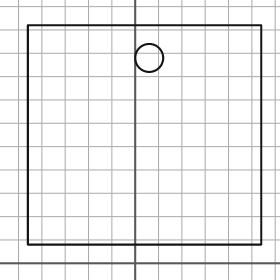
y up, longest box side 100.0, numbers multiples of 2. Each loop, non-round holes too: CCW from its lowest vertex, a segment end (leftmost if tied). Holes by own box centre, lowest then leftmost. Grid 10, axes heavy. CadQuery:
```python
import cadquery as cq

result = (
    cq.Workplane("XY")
    .moveTo(-46.0, 8.0)
    .lineTo(54.0, 8.0)
    .lineTo(54.0, 102.0)
    .lineTo(-46.0, 102.0)
    .close()
    .moveTo(6.0, 88.0)
    .circle(6.0)
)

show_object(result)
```